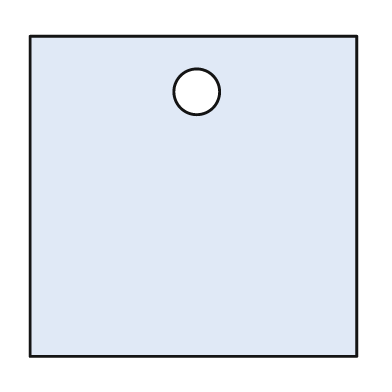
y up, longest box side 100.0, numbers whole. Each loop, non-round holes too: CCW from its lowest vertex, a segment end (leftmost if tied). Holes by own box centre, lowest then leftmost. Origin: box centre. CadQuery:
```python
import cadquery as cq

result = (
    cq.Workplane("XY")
    .moveTo(-50.0, -49.0)
    .lineTo(50.0, -49.0)
    .lineTo(50.0, 49.0)
    .lineTo(-50.0, 49.0)
    .close()
    .moveTo(1.0, 32.0)
    .circle(7.0)
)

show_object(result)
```